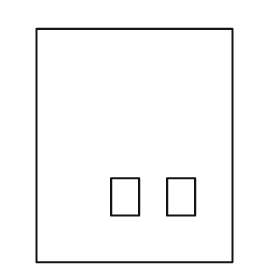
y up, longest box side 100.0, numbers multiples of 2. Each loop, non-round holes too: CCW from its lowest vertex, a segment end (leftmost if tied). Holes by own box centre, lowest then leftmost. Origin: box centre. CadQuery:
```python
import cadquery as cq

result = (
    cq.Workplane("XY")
    .moveTo(-42.0, -50.0)
    .lineTo(42.0, -50.0)
    .lineTo(42.0, 50.0)
    .lineTo(-42.0, 50.0)
    .close()
    .moveTo(-10.0, -30.0)
    .lineTo(2.0, -30.0)
    .lineTo(2.0, -14.0)
    .lineTo(-10.0, -14.0)
    .close()
    .moveTo(14.0, -30.0)
    .lineTo(26.0, -30.0)
    .lineTo(26.0, -14.0)
    .lineTo(14.0, -14.0)
    .close()
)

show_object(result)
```